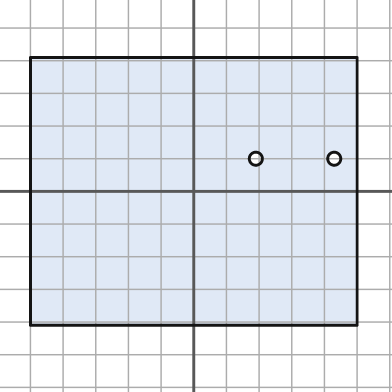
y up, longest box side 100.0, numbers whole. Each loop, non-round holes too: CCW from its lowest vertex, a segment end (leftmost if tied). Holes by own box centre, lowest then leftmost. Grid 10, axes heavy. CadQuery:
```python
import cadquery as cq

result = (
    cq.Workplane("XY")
    .moveTo(-50.0, -41.0)
    .lineTo(50.0, -41.0)
    .lineTo(50.0, 41.0)
    .lineTo(-50.0, 41.0)
    .close()
    .moveTo(19.0, 10.0)
    .circle(2.0)
    .moveTo(43.0, 10.0)
    .circle(2.0)
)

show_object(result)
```